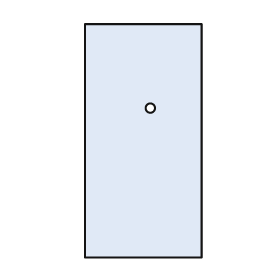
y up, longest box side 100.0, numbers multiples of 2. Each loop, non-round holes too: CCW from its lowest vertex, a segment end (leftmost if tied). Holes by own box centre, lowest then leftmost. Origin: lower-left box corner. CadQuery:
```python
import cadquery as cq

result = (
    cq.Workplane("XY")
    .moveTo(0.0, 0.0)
    .lineTo(50.0, 0.0)
    .lineTo(50.0, 100.0)
    .lineTo(0.0, 100.0)
    .close()
    .moveTo(28.0, 64.0)
    .circle(2.0)
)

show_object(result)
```